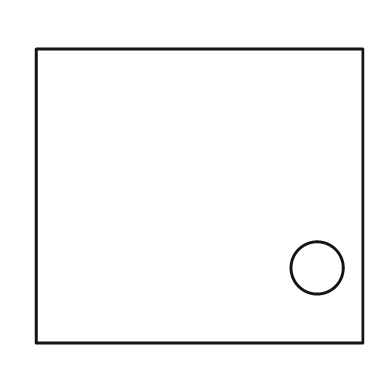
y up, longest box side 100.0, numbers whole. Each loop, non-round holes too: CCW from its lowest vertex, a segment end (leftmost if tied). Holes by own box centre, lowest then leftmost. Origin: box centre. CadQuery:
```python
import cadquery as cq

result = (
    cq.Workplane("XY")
    .moveTo(-50.0, -45.0)
    .lineTo(50.0, -45.0)
    .lineTo(50.0, 45.0)
    .lineTo(-50.0, 45.0)
    .close()
    .moveTo(36.0, -22.0)
    .circle(8.0)
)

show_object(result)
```